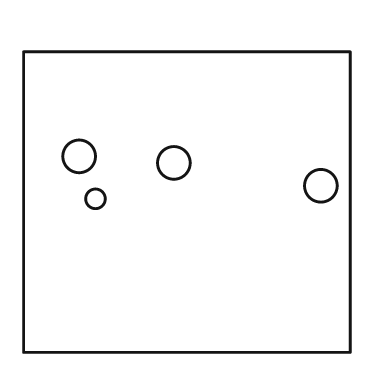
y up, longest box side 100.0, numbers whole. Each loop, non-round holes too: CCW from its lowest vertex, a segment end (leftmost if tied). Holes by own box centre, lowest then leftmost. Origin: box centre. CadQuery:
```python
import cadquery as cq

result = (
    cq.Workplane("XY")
    .moveTo(-50.0, -46.0)
    .lineTo(50.0, -46.0)
    .lineTo(50.0, 46.0)
    .lineTo(-50.0, 46.0)
    .close()
    .moveTo(-28.0, 1.0)
    .circle(3.0)
    .moveTo(41.0, 5.0)
    .circle(5.0)
    .moveTo(-4.0, 12.0)
    .circle(5.0)
    .moveTo(-33.0, 14.0)
    .circle(5.0)
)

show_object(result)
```